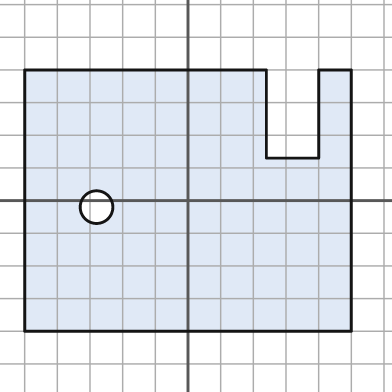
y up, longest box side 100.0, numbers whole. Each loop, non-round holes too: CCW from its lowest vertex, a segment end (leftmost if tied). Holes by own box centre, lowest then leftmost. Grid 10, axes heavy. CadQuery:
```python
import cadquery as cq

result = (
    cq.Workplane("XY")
    .moveTo(-50.0, -40.0)
    .lineTo(50.0, -40.0)
    .lineTo(50.0, 40.0)
    .lineTo(40.0, 40.0)
    .lineTo(40.0, 13.0)
    .lineTo(24.0, 13.0)
    .lineTo(24.0, 40.0)
    .lineTo(-50.0, 40.0)
    .close()
    .moveTo(-28.0, -2.0)
    .circle(5.0)
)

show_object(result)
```